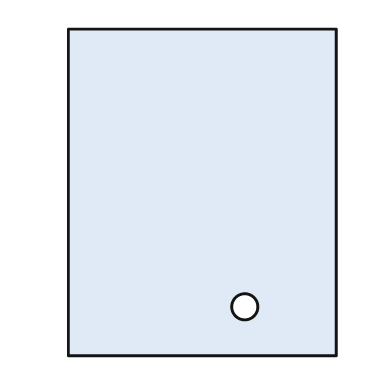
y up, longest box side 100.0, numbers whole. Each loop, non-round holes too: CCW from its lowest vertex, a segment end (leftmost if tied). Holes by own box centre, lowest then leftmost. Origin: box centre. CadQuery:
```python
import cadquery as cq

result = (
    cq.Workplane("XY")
    .moveTo(-41.0, -50.0)
    .lineTo(41.0, -50.0)
    .lineTo(41.0, 50.0)
    .lineTo(-41.0, 50.0)
    .close()
    .moveTo(13.0, -35.0)
    .circle(4.0)
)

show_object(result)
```